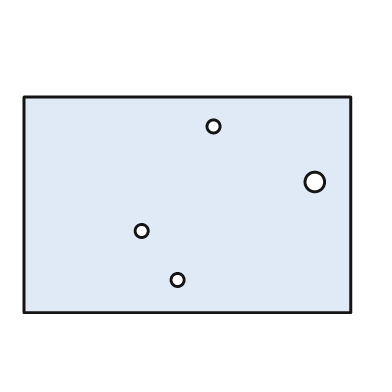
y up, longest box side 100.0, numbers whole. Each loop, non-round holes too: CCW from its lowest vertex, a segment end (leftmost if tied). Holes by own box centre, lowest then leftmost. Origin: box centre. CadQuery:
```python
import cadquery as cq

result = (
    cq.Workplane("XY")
    .moveTo(-50.0, -33.0)
    .lineTo(50.0, -33.0)
    .lineTo(50.0, 33.0)
    .lineTo(-50.0, 33.0)
    .close()
    .moveTo(-3.0, -23.0)
    .circle(2.0)
    .moveTo(-14.0, -8.0)
    .circle(2.0)
    .moveTo(39.0, 7.0)
    .circle(3.0)
    .moveTo(8.0, 24.0)
    .circle(2.0)
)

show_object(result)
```